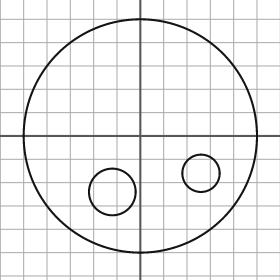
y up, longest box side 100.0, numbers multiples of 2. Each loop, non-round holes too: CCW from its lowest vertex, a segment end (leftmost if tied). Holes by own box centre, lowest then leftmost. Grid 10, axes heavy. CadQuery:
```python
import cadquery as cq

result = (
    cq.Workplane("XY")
    .moveTo(0.0, 0.0)
    .circle(50.0)
    .moveTo(-12.0, -24.0)
    .circle(10.0)
    .moveTo(26.0, -16.0)
    .circle(8.0)
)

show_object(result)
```